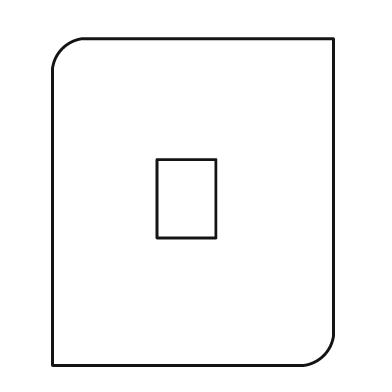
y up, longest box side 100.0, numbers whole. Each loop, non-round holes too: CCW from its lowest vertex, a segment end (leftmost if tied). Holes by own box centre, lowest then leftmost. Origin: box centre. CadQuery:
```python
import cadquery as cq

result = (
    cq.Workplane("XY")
    .moveTo(-43.0, -50.0)
    .lineTo(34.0, -50.0)
    .threePointArc((40.0, -47.0), (43.0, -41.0))
    .lineTo(43.0, 50.0)
    .lineTo(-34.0, 50.0)
    .threePointArc((-40.0, 47.0), (-43.0, 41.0))
    .close()
    .moveTo(-11.0, -11.0)
    .lineTo(7.0, -11.0)
    .lineTo(7.0, 13.0)
    .lineTo(-11.0, 13.0)
    .close()
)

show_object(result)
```